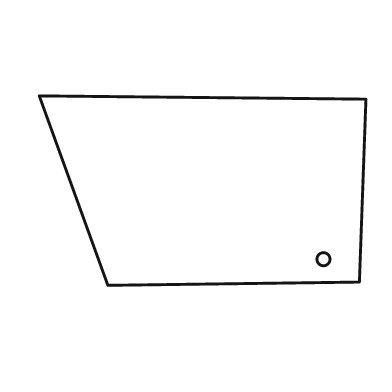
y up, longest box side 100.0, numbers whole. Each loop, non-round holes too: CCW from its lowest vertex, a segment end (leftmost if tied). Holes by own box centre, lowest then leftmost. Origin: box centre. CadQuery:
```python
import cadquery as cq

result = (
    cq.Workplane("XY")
    .moveTo(-29.0, -29.0)
    .lineTo(48.0, -28.0)
    .lineTo(50.0, 28.0)
    .lineTo(-50.0, 29.0)
    .close()
    .moveTo(37.0, -21.0)
    .circle(2.0)
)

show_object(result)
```